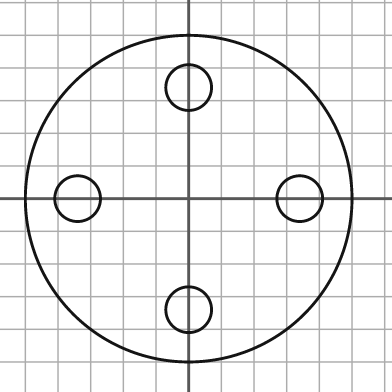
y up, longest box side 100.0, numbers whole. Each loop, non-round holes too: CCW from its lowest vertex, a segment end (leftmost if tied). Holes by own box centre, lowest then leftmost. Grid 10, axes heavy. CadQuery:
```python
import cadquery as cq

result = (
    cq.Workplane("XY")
    .moveTo(0.0, 0.0)
    .circle(50.0)
    .moveTo(0.0, -34.0)
    .circle(7.0)
    .moveTo(-34.0, 0.0)
    .circle(7.0)
    .moveTo(34.0, 0.0)
    .circle(7.0)
    .moveTo(0.0, 34.0)
    .circle(7.0)
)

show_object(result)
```